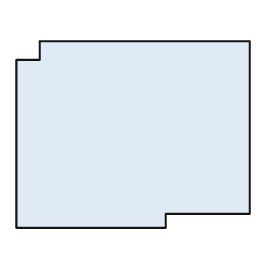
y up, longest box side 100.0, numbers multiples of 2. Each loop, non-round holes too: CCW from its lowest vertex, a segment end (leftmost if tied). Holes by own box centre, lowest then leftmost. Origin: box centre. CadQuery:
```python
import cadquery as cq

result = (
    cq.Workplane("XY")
    .moveTo(-50.0, -40.0)
    .lineTo(14.0, -40.0)
    .lineTo(14.0, -34.0)
    .lineTo(50.0, -34.0)
    .lineTo(50.0, 40.0)
    .lineTo(-40.0, 40.0)
    .lineTo(-40.0, 32.0)
    .lineTo(-50.0, 32.0)
    .close()
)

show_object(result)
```